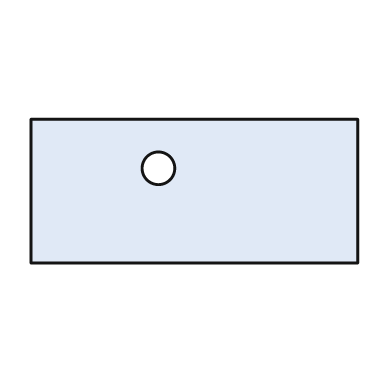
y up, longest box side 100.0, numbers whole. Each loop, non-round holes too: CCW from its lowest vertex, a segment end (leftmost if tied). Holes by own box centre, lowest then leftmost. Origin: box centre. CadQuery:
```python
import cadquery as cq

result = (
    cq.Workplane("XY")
    .moveTo(-50.0, -22.0)
    .lineTo(50.0, -22.0)
    .lineTo(50.0, 22.0)
    .lineTo(-50.0, 22.0)
    .close()
    .moveTo(-11.0, 7.0)
    .circle(5.0)
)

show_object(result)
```